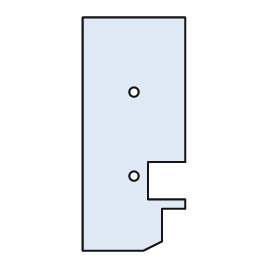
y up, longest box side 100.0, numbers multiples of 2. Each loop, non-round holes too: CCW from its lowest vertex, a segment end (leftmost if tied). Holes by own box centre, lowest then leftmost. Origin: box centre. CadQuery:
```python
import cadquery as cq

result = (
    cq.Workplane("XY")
    .moveTo(-22.0, -50.0)
    .lineTo(4.0, -50.0)
    .lineTo(12.0, -46.0)
    .lineTo(12.0, -32.0)
    .lineTo(22.0, -32.0)
    .lineTo(22.0, -28.0)
    .lineTo(6.0, -28.0)
    .lineTo(6.0, -12.0)
    .lineTo(22.0, -12.0)
    .lineTo(22.0, 50.0)
    .lineTo(-22.0, 50.0)
    .close()
    .moveTo(0.0, -18.0)
    .circle(2.0)
    .moveTo(0.0, 18.0)
    .circle(2.0)
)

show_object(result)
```